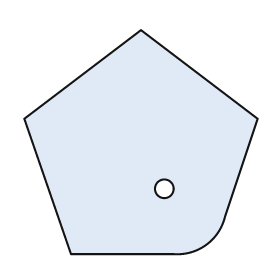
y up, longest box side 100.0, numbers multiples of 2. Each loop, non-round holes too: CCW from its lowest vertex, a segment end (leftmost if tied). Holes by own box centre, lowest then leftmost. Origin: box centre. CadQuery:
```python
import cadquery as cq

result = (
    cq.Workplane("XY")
    .moveTo(-30.0, -48.0)
    .lineTo(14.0, -48.0)
    .threePointArc((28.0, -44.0), (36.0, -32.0))
    .lineTo(50.0, 10.0)
    .lineTo(0.0, 48.0)
    .lineTo(-50.0, 10.0)
    .close()
    .moveTo(10.0, -20.0)
    .circle(4.0)
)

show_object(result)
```